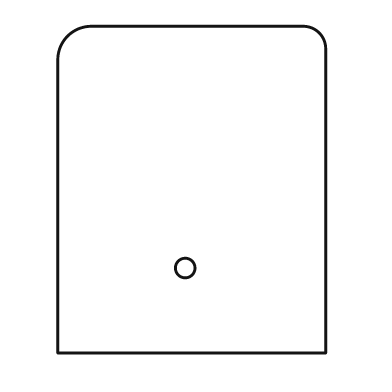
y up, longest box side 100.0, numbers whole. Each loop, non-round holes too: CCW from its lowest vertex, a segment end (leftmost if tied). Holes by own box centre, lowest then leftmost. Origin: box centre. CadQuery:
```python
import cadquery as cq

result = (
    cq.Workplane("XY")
    .moveTo(-41.0, -50.0)
    .lineTo(41.0, -50.0)
    .lineTo(41.0, 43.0)
    .threePointArc((39.0, 48.0), (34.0, 50.0))
    .lineTo(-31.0, 50.0)
    .threePointArc((-38.0, 47.0), (-41.0, 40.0))
    .close()
    .moveTo(-2.0, -24.0)
    .circle(3.0)
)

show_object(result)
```